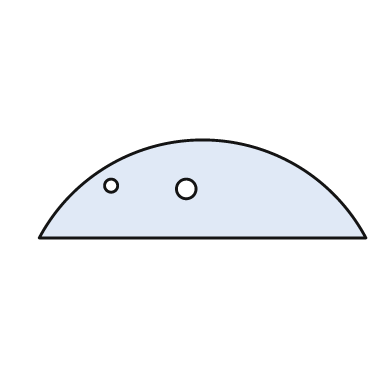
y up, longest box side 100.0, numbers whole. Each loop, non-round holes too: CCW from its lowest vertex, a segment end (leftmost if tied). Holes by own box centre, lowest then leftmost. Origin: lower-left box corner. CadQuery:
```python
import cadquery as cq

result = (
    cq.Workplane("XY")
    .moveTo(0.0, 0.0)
    .lineTo(100.0, 0.0)
    .threePointArc((50.0, 30.0), (0.0, 0.0))
    .close()
    .moveTo(45.0, 15.0)
    .circle(3.0)
    .moveTo(22.0, 16.0)
    .circle(2.0)
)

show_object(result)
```